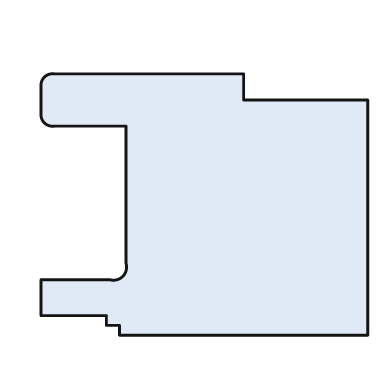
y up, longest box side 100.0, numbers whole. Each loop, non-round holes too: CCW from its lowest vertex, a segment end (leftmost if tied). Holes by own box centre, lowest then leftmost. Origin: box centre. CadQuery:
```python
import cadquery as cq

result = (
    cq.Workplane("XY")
    .moveTo(-26.0, -40.0)
    .lineTo(50.0, -40.0)
    .lineTo(50.0, 32.0)
    .lineTo(12.0, 32.0)
    .lineTo(12.0, 40.0)
    .lineTo(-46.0, 40.0)
    .threePointArc((-49.0, 39.0), (-50.0, 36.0))
    .lineTo(-50.0, 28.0)
    .threePointArc((-49.0, 25.0), (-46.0, 24.0))
    .lineTo(-24.0, 24.0)
    .lineTo(-24.0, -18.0)
    .threePointArc((-25.0, -22.0), (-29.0, -23.0))
    .lineTo(-50.0, -23.0)
    .lineTo(-50.0, -34.0)
    .lineTo(-30.0, -34.0)
    .lineTo(-30.0, -37.0)
    .lineTo(-26.0, -37.0)
    .close()
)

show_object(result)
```